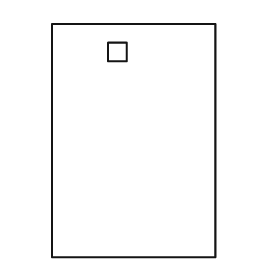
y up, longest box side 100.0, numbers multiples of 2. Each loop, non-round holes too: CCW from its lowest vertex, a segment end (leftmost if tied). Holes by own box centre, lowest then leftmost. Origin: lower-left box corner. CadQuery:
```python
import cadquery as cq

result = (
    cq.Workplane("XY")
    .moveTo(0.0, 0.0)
    .lineTo(70.0, 0.0)
    .lineTo(70.0, 100.0)
    .lineTo(0.0, 100.0)
    .close()
    .moveTo(24.0, 84.0)
    .lineTo(32.0, 84.0)
    .lineTo(32.0, 92.0)
    .lineTo(24.0, 92.0)
    .close()
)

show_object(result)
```